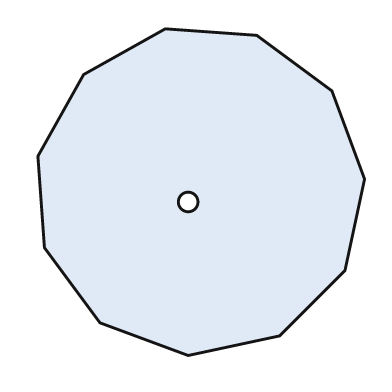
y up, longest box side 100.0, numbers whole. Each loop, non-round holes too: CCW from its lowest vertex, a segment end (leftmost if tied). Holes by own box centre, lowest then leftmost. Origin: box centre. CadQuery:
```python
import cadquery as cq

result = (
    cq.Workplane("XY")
    .moveTo(-4.0, -50.0)
    .lineTo(24.0, -44.0)
    .lineTo(44.0, -24.0)
    .lineTo(50.0, 4.0)
    .lineTo(40.0, 31.0)
    .lineTo(17.0, 48.0)
    .lineTo(-11.0, 50.0)
    .lineTo(-36.0, 36.0)
    .lineTo(-50.0, 11.0)
    .lineTo(-48.0, -17.0)
    .lineTo(-31.0, -40.0)
    .close()
    .moveTo(-4.0, -3.0)
    .circle(3.0)
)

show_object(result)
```